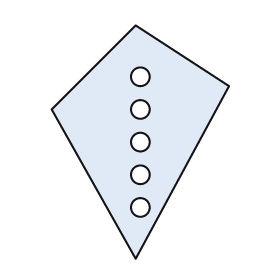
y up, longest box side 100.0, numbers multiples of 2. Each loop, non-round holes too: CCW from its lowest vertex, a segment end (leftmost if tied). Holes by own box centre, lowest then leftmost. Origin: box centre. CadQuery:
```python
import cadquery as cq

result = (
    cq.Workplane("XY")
    .moveTo(-2.0, -50.0)
    .lineTo(38.0, 24.0)
    .lineTo(-2.0, 50.0)
    .lineTo(-38.0, 14.0)
    .close()
    .moveTo(0.0, -28.0)
    .circle(4.0)
    .moveTo(0.0, -14.0)
    .circle(4.0)
    .moveTo(0.0, 0.0)
    .circle(4.0)
    .moveTo(0.0, 14.0)
    .circle(4.0)
    .moveTo(0.0, 28.0)
    .circle(4.0)
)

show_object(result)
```